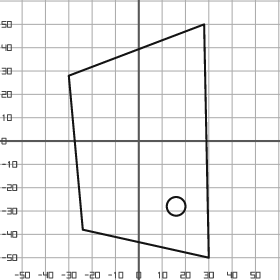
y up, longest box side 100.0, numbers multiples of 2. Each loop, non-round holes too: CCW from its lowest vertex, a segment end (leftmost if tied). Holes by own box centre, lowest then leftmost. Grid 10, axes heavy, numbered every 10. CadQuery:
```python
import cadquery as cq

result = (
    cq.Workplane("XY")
    .moveTo(30.0, -50.0)
    .lineTo(28.0, 50.0)
    .lineTo(-30.0, 28.0)
    .lineTo(-24.0, -38.0)
    .close()
    .moveTo(16.0, -28.0)
    .circle(4.0)
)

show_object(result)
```